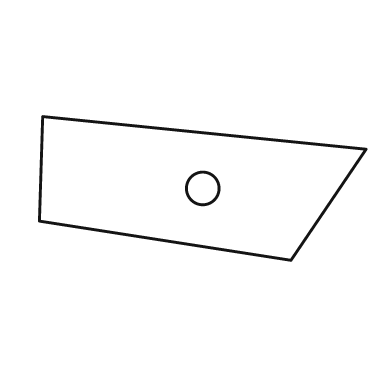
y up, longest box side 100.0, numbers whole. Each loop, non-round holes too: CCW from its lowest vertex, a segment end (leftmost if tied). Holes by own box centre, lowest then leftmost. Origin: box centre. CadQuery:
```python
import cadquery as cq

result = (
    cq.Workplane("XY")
    .moveTo(27.0, -22.0)
    .lineTo(50.0, 12.0)
    .lineTo(-49.0, 22.0)
    .lineTo(-50.0, -10.0)
    .close()
    .moveTo(0.0, 0.0)
    .circle(5.0)
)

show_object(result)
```